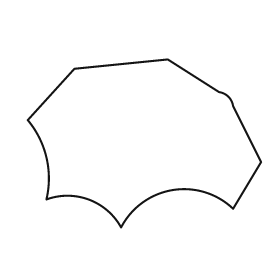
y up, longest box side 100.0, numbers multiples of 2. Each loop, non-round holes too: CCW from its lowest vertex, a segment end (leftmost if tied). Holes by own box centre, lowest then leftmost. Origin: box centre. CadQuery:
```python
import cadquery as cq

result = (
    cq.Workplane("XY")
    .moveTo(-10.0, -36.0)
    .threePointArc((12.0, -20.0), (38.0, -28.0))
    .lineTo(50.0, -8.0)
    .lineTo(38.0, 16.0)
    .threePointArc((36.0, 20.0), (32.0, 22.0))
    .lineTo(10.0, 36.0)
    .lineTo(-30.0, 32.0)
    .lineTo(-50.0, 10.0)
    .threePointArc((-42.0, -6.0), (-42.0, -24.0))
    .threePointArc((-24.0, -24.0), (-10.0, -36.0))
    .close()
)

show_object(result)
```